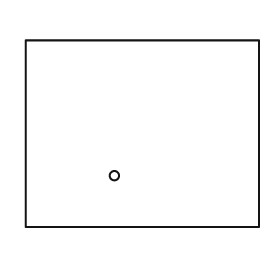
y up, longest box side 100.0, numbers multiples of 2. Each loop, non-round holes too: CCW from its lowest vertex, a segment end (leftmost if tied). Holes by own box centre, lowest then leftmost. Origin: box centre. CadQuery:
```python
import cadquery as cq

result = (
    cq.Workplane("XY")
    .moveTo(-50.0, -40.0)
    .lineTo(50.0, -40.0)
    .lineTo(50.0, 40.0)
    .lineTo(-50.0, 40.0)
    .close()
    .moveTo(-12.0, -18.0)
    .circle(2.0)
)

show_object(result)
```